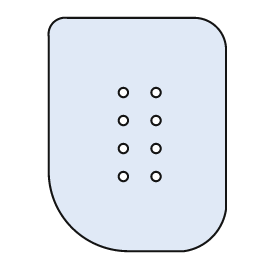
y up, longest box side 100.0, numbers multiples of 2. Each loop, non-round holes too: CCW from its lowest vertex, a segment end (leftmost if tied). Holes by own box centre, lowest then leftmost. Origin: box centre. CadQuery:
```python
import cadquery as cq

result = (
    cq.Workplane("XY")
    .moveTo(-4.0, -50.0)
    .lineTo(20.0, -50.0)
    .threePointArc((32.0, -44.0), (38.0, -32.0))
    .lineTo(38.0, 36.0)
    .threePointArc((34.0, 46.0), (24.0, 50.0))
    .lineTo(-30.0, 50.0)
    .threePointArc((-36.0, 48.0), (-38.0, 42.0))
    .lineTo(-38.0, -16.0)
    .threePointArc((-28.0, -40.0), (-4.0, -50.0))
    .close()
    .moveTo(-6.0, -18.0)
    .circle(2.0)
    .moveTo(8.0, -18.0)
    .circle(2.0)
    .moveTo(-6.0, -6.0)
    .circle(2.0)
    .moveTo(8.0, -6.0)
    .circle(2.0)
    .moveTo(-6.0, 6.0)
    .circle(2.0)
    .moveTo(8.0, 6.0)
    .circle(2.0)
    .moveTo(-6.0, 18.0)
    .circle(2.0)
    .moveTo(8.0, 18.0)
    .circle(2.0)
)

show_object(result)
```